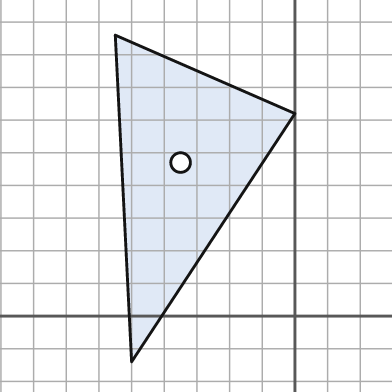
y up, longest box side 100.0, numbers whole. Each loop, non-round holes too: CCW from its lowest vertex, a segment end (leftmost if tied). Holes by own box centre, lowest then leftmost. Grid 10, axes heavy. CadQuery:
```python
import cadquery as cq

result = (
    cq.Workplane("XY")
    .moveTo(-50.0, -14.0)
    .lineTo(0.0, 62.0)
    .lineTo(-55.0, 86.0)
    .close()
    .moveTo(-35.0, 47.0)
    .circle(3.0)
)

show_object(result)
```